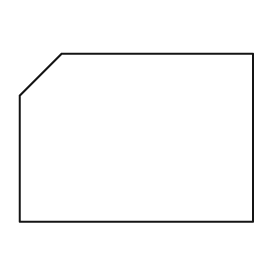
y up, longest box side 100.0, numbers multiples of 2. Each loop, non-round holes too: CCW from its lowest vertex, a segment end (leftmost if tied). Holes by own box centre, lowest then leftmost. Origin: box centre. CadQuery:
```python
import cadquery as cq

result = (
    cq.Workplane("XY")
    .moveTo(-50.0, -36.0)
    .lineTo(50.0, -36.0)
    .lineTo(50.0, 36.0)
    .lineTo(-32.0, 36.0)
    .lineTo(-50.0, 18.0)
    .close()
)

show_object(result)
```